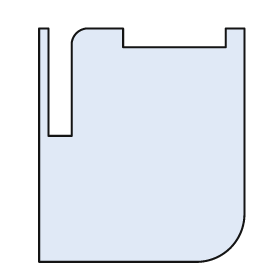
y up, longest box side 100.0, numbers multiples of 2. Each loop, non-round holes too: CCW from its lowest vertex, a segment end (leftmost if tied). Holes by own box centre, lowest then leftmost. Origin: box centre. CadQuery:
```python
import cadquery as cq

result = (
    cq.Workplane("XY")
    .moveTo(-44.0, -50.0)
    .lineTo(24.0, -50.0)
    .threePointArc((38.0, -44.0), (44.0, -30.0))
    .lineTo(44.0, 50.0)
    .lineTo(36.0, 50.0)
    .lineTo(36.0, 42.0)
    .lineTo(-8.0, 42.0)
    .lineTo(-8.0, 50.0)
    .lineTo(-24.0, 50.0)
    .threePointArc((-28.0, 48.0), (-30.0, 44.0))
    .lineTo(-30.0, 4.0)
    .lineTo(-40.0, 4.0)
    .lineTo(-40.0, 50.0)
    .lineTo(-44.0, 50.0)
    .close()
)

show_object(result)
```